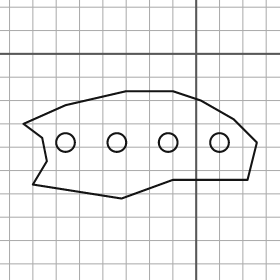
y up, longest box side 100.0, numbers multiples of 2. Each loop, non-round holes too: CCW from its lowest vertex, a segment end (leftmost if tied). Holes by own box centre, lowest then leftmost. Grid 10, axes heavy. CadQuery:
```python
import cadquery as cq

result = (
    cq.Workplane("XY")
    .moveTo(-32.0, -62.0)
    .lineTo(-10.0, -54.0)
    .lineTo(22.0, -54.0)
    .lineTo(26.0, -38.0)
    .lineTo(16.0, -28.0)
    .lineTo(2.0, -20.0)
    .lineTo(-10.0, -16.0)
    .lineTo(-30.0, -16.0)
    .lineTo(-56.0, -22.0)
    .lineTo(-74.0, -30.0)
    .lineTo(-66.0, -36.0)
    .lineTo(-64.0, -46.0)
    .lineTo(-70.0, -56.0)
    .close()
    .moveTo(-56.0, -38.0)
    .circle(4.0)
    .moveTo(-34.0, -38.0)
    .circle(4.0)
    .moveTo(-12.0, -38.0)
    .circle(4.0)
    .moveTo(10.0, -38.0)
    .circle(4.0)
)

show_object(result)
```